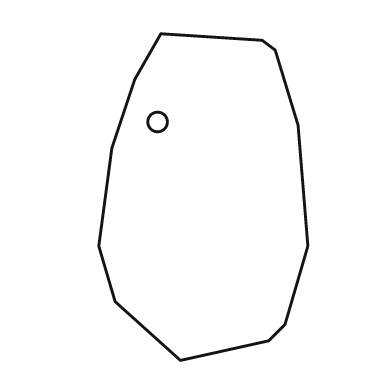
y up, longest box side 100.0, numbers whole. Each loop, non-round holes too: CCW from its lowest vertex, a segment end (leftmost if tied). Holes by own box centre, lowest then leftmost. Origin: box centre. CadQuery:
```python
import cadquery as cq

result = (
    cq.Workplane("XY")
    .moveTo(-7.0, -50.0)
    .lineTo(20.0, -44.0)
    .lineTo(25.0, -39.0)
    .lineTo(32.0, -15.0)
    .lineTo(29.0, 22.0)
    .lineTo(22.0, 45.0)
    .lineTo(18.0, 48.0)
    .lineTo(-13.0, 50.0)
    .lineTo(-21.0, 36.0)
    .lineTo(-28.0, 15.0)
    .lineTo(-32.0, -15.0)
    .lineTo(-27.0, -32.0)
    .close()
    .moveTo(-14.0, 23.0)
    .circle(3.0)
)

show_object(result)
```